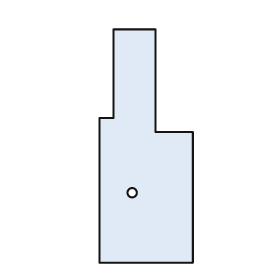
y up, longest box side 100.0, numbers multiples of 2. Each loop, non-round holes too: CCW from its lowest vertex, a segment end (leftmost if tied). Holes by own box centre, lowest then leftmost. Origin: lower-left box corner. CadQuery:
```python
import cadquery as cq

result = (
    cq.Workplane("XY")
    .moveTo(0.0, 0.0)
    .lineTo(40.0, 0.0)
    .lineTo(40.0, 56.0)
    .lineTo(24.0, 56.0)
    .lineTo(24.0, 100.0)
    .lineTo(6.0, 100.0)
    .lineTo(6.0, 62.0)
    .lineTo(0.0, 62.0)
    .close()
    .moveTo(14.0, 30.0)
    .circle(2.0)
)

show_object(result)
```